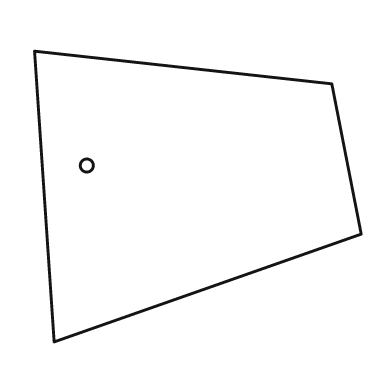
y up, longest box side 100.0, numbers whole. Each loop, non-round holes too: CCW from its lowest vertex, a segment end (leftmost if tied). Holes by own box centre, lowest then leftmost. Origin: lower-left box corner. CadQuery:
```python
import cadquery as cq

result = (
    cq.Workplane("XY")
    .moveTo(6.0, 0.0)
    .lineTo(100.0, 33.0)
    .lineTo(91.0, 79.0)
    .lineTo(0.0, 89.0)
    .close()
    .moveTo(16.0, 54.0)
    .circle(2.0)
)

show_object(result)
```